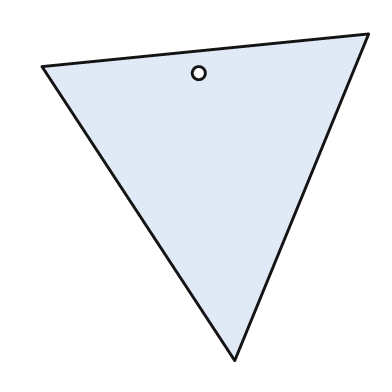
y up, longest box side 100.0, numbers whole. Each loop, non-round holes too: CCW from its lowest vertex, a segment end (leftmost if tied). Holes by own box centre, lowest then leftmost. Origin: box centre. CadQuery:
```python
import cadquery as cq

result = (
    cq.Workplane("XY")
    .moveTo(9.0, -50.0)
    .lineTo(50.0, 50.0)
    .lineTo(-50.0, 40.0)
    .close()
    .moveTo(-2.0, 38.0)
    .circle(2.0)
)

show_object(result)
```